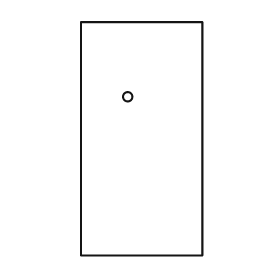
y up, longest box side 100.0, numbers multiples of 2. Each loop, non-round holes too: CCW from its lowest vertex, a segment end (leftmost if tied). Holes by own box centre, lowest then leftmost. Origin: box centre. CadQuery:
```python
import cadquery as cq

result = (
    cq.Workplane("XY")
    .moveTo(-26.0, -50.0)
    .lineTo(26.0, -50.0)
    .lineTo(26.0, 50.0)
    .lineTo(-26.0, 50.0)
    .close()
    .moveTo(-6.0, 18.0)
    .circle(2.0)
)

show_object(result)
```